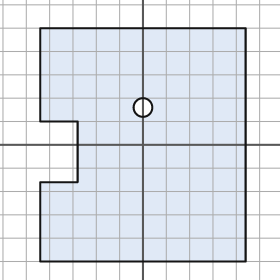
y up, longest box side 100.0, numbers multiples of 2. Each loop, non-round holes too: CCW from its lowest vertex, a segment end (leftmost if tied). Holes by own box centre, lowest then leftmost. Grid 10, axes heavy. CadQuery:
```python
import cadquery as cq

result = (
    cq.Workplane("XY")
    .moveTo(-44.0, -50.0)
    .lineTo(44.0, -50.0)
    .lineTo(44.0, 50.0)
    .lineTo(-44.0, 50.0)
    .lineTo(-44.0, 10.0)
    .lineTo(-28.0, 10.0)
    .lineTo(-28.0, -16.0)
    .lineTo(-44.0, -16.0)
    .close()
    .moveTo(0.0, 16.0)
    .circle(4.0)
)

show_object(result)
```